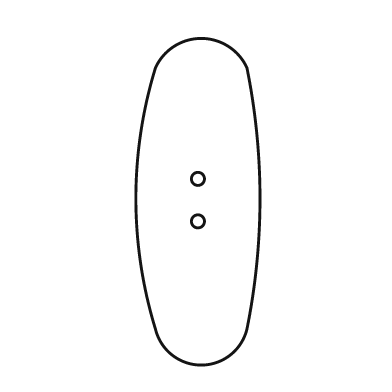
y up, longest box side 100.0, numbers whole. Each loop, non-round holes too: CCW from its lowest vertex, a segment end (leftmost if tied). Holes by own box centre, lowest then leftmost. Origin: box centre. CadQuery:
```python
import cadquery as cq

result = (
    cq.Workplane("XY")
    .moveTo(-13.0, -39.0)
    .threePointArc((1.0, -50.0), (15.0, -39.0))
    .threePointArc((19.0, 1.0), (15.0, 41.0))
    .threePointArc((1.0, 50.0), (-13.0, 41.0))
    .threePointArc((-19.0, 1.0), (-13.0, -39.0))
    .close()
    .moveTo(0.0, -6.0)
    .circle(2.0)
    .moveTo(0.0, 7.0)
    .circle(2.0)
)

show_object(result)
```